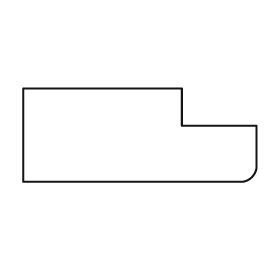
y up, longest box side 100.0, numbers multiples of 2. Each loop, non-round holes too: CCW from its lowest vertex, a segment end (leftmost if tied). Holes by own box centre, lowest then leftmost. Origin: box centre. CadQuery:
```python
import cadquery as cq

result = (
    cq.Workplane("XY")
    .moveTo(-50.0, -20.0)
    .lineTo(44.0, -20.0)
    .threePointArc((48.0, -18.0), (50.0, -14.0))
    .lineTo(50.0, 4.0)
    .lineTo(18.0, 4.0)
    .lineTo(18.0, 20.0)
    .lineTo(-50.0, 20.0)
    .close()
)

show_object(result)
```